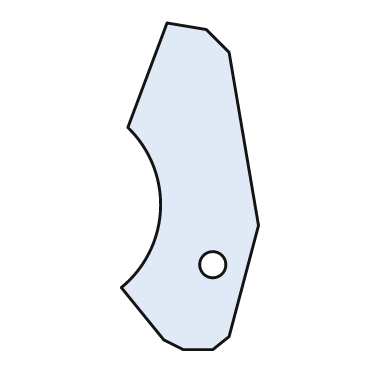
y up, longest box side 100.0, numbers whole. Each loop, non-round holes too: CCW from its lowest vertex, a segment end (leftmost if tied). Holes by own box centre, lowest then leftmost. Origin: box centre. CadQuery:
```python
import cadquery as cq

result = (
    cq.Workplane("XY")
    .moveTo(-2.0, -50.0)
    .lineTo(7.0, -50.0)
    .lineTo(12.0, -46.0)
    .lineTo(21.0, -12.0)
    .lineTo(12.0, 41.0)
    .lineTo(5.0, 48.0)
    .lineTo(-7.0, 50.0)
    .lineTo(-19.0, 18.0)
    .threePointArc((-9.0, -7.0), (-21.0, -31.0))
    .lineTo(-8.0, -47.0)
    .close()
    .moveTo(7.0, -24.0)
    .circle(4.0)
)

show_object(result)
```